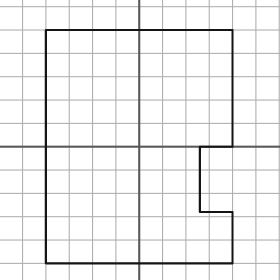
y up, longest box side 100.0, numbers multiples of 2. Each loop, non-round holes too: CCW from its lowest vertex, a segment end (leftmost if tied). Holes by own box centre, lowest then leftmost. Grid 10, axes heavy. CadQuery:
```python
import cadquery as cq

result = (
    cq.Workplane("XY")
    .moveTo(-40.0, -50.0)
    .lineTo(40.0, -50.0)
    .lineTo(40.0, -28.0)
    .lineTo(26.0, -28.0)
    .lineTo(26.0, 0.0)
    .lineTo(40.0, 0.0)
    .lineTo(40.0, 50.0)
    .lineTo(-40.0, 50.0)
    .close()
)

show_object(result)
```